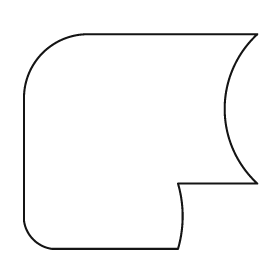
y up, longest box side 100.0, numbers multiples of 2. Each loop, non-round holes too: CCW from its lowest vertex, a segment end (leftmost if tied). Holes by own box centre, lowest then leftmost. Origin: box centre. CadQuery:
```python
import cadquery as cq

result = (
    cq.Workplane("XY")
    .moveTo(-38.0, -46.0)
    .lineTo(16.0, -46.0)
    .threePointArc((18.0, -32.0), (16.0, -18.0))
    .lineTo(50.0, -18.0)
    .threePointArc((36.0, 14.0), (50.0, 46.0))
    .lineTo(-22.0, 46.0)
    .threePointArc((-42.0, 38.0), (-50.0, 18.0))
    .lineTo(-50.0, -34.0)
    .threePointArc((-46.0, -42.0), (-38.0, -46.0))
    .close()
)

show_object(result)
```